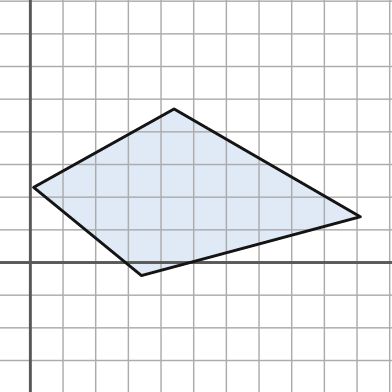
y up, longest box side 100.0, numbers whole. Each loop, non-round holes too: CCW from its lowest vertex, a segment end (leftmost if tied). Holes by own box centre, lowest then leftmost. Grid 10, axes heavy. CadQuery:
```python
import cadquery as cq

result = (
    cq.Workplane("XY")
    .moveTo(34.0, -4.0)
    .lineTo(101.0, 14.0)
    .lineTo(44.0, 47.0)
    .lineTo(1.0, 23.0)
    .close()
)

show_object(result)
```